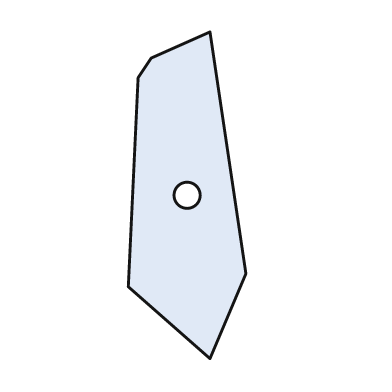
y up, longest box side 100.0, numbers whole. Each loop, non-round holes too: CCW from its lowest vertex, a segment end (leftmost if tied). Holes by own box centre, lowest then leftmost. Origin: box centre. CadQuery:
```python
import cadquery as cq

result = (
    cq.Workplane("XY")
    .moveTo(7.0, -50.0)
    .lineTo(18.0, -24.0)
    .lineTo(7.0, 50.0)
    .lineTo(-11.0, 42.0)
    .lineTo(-15.0, 36.0)
    .lineTo(-18.0, -28.0)
    .close()
    .moveTo(0.0, 0.0)
    .circle(4.0)
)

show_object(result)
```